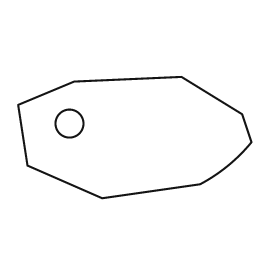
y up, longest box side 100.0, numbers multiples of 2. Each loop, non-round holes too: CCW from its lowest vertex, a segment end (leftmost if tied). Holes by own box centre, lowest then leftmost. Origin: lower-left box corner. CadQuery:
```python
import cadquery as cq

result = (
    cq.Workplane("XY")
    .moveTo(36.0, 0.0)
    .lineTo(78.0, 6.0)
    .threePointArc((90.0, 14.0), (100.0, 24.0))
    .lineTo(96.0, 36.0)
    .lineTo(70.0, 52.0)
    .lineTo(24.0, 50.0)
    .lineTo(0.0, 40.0)
    .lineTo(4.0, 14.0)
    .close()
    .moveTo(22.0, 32.0)
    .circle(6.0)
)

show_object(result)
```